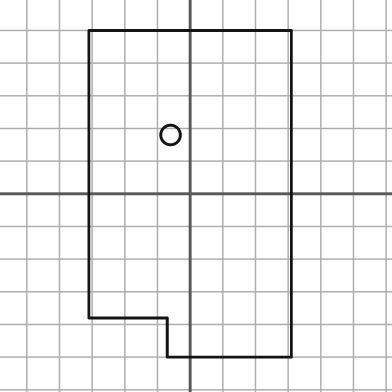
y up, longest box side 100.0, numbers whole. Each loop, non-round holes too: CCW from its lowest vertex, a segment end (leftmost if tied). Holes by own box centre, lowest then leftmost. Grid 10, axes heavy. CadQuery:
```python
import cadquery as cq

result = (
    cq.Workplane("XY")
    .moveTo(-7.0, -50.0)
    .lineTo(31.0, -50.0)
    .lineTo(31.0, 50.0)
    .lineTo(-31.0, 50.0)
    .lineTo(-31.0, -38.0)
    .lineTo(-7.0, -38.0)
    .close()
    .moveTo(-6.0, 18.0)
    .circle(3.0)
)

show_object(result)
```